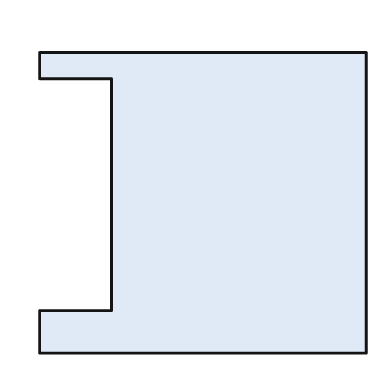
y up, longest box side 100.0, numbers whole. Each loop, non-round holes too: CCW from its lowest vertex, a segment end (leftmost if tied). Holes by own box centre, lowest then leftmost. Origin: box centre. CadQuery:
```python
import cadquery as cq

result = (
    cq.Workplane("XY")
    .moveTo(-50.0, -46.0)
    .lineTo(50.0, -46.0)
    .lineTo(50.0, 46.0)
    .lineTo(-50.0, 46.0)
    .lineTo(-50.0, 38.0)
    .lineTo(-28.0, 38.0)
    .lineTo(-28.0, -33.0)
    .lineTo(-50.0, -33.0)
    .close()
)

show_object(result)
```